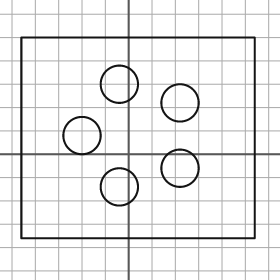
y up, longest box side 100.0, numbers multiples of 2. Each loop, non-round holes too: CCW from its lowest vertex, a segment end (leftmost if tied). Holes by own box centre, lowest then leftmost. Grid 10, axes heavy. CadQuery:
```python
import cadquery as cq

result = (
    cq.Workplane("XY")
    .moveTo(-46.0, -36.0)
    .lineTo(54.0, -36.0)
    .lineTo(54.0, 50.0)
    .lineTo(-46.0, 50.0)
    .close()
    .moveTo(-4.0, -14.0)
    .circle(8.0)
    .moveTo(22.0, -6.0)
    .circle(8.0)
    .moveTo(-20.0, 8.0)
    .circle(8.0)
    .moveTo(22.0, 22.0)
    .circle(8.0)
    .moveTo(-4.0, 30.0)
    .circle(8.0)
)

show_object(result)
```